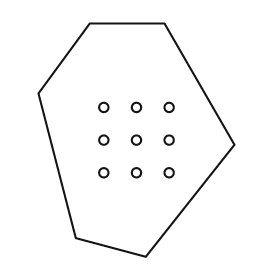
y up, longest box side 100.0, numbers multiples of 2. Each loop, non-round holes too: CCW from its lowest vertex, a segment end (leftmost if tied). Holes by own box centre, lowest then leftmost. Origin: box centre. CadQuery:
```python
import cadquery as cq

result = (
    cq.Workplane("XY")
    .moveTo(4.0, -50.0)
    .lineTo(42.0, -2.0)
    .lineTo(12.0, 50.0)
    .lineTo(-20.0, 50.0)
    .lineTo(-42.0, 20.0)
    .lineTo(-26.0, -42.0)
    .close()
    .moveTo(-14.0, -14.0)
    .circle(2.0)
    .moveTo(0.0, -14.0)
    .circle(2.0)
    .moveTo(14.0, -14.0)
    .circle(2.0)
    .moveTo(-14.0, 0.0)
    .circle(2.0)
    .moveTo(0.0, 0.0)
    .circle(2.0)
    .moveTo(14.0, 0.0)
    .circle(2.0)
    .moveTo(-14.0, 14.0)
    .circle(2.0)
    .moveTo(0.0, 14.0)
    .circle(2.0)
    .moveTo(14.0, 14.0)
    .circle(2.0)
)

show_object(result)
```